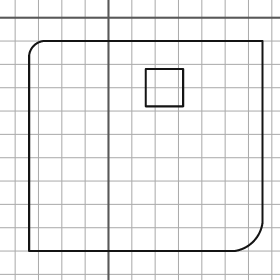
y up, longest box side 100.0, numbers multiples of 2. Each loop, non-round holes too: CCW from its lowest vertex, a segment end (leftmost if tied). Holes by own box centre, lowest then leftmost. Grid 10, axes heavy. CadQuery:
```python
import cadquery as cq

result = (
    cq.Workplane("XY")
    .moveTo(-34.0, -100.0)
    .lineTo(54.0, -100.0)
    .threePointArc((62.0, -96.0), (66.0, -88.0))
    .lineTo(66.0, -10.0)
    .lineTo(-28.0, -10.0)
    .threePointArc((-32.0, -12.0), (-34.0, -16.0))
    .close()
    .moveTo(16.0, -38.0)
    .lineTo(32.0, -38.0)
    .lineTo(32.0, -22.0)
    .lineTo(16.0, -22.0)
    .close()
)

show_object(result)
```